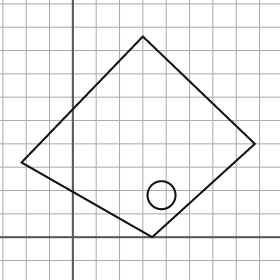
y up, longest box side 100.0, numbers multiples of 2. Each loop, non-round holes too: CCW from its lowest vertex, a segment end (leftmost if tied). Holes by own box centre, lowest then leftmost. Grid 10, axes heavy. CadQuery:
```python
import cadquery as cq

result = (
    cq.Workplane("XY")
    .moveTo(34.0, 0.0)
    .lineTo(78.0, 40.0)
    .lineTo(30.0, 86.0)
    .lineTo(-22.0, 32.0)
    .close()
    .moveTo(38.0, 18.0)
    .circle(6.0)
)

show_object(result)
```